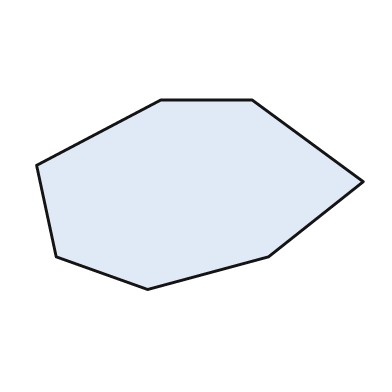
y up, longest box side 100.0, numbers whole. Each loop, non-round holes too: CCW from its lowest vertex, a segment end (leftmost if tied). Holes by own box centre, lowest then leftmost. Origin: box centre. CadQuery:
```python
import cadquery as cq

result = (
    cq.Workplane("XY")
    .moveTo(-16.0, -29.0)
    .lineTo(21.0, -19.0)
    .lineTo(50.0, 4.0)
    .lineTo(16.0, 29.0)
    .lineTo(-12.0, 29.0)
    .lineTo(-50.0, 9.0)
    .lineTo(-44.0, -19.0)
    .close()
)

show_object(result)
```